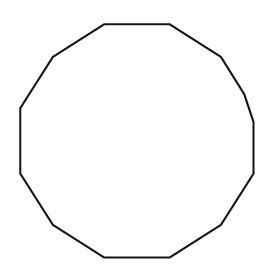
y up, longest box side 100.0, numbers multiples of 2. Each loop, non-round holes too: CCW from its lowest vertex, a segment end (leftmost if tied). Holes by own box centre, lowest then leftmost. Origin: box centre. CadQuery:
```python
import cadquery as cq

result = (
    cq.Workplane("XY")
    .moveTo(-14.0, -50.0)
    .lineTo(14.0, -50.0)
    .lineTo(36.0, -36.0)
    .lineTo(50.0, -14.0)
    .lineTo(50.0, 8.0)
    .lineTo(46.0, 20.0)
    .lineTo(36.0, 36.0)
    .lineTo(14.0, 50.0)
    .lineTo(-14.0, 50.0)
    .lineTo(-36.0, 36.0)
    .lineTo(-50.0, 14.0)
    .lineTo(-50.0, -14.0)
    .lineTo(-36.0, -36.0)
    .close()
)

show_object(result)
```